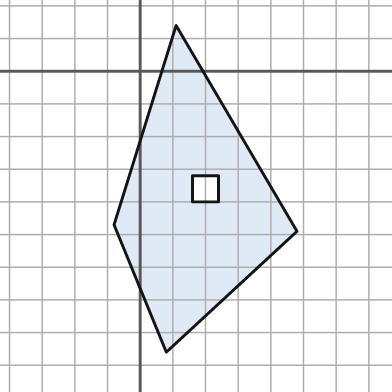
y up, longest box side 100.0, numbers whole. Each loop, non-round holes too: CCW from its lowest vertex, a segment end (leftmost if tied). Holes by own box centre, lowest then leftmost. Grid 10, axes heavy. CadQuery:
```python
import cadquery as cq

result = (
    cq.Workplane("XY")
    .moveTo(8.0, -86.0)
    .lineTo(48.0, -49.0)
    .lineTo(11.0, 14.0)
    .lineTo(-8.0, -47.0)
    .close()
    .moveTo(16.0, -40.0)
    .lineTo(24.0, -40.0)
    .lineTo(24.0, -32.0)
    .lineTo(16.0, -32.0)
    .close()
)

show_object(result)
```